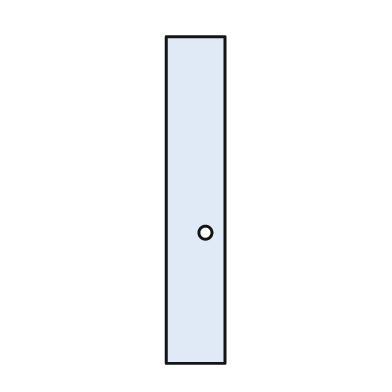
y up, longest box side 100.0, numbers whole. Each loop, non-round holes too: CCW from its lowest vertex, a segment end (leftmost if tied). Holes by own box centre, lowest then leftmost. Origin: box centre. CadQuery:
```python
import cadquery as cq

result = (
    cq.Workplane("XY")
    .moveTo(-9.0, -50.0)
    .lineTo(9.0, -50.0)
    .lineTo(9.0, 50.0)
    .lineTo(-9.0, 50.0)
    .close()
    .moveTo(3.0, -10.0)
    .circle(2.0)
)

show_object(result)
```